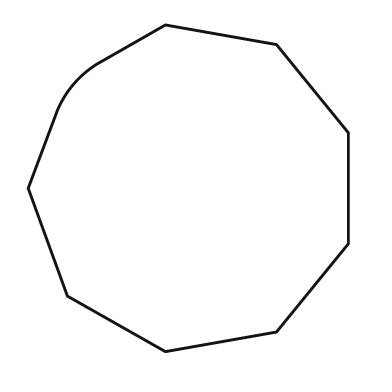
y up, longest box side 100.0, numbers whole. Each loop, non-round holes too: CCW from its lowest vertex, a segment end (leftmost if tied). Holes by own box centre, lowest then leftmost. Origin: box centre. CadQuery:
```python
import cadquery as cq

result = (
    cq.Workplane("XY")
    .moveTo(-7.0, -50.0)
    .lineTo(27.0, -44.0)
    .lineTo(49.0, -17.0)
    .lineTo(49.0, 17.0)
    .lineTo(27.0, 44.0)
    .lineTo(-7.0, 50.0)
    .lineTo(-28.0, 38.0)
    .threePointArc((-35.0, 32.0), (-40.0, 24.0))
    .lineTo(-49.0, 0.0)
    .lineTo(-37.0, -33.0)
    .close()
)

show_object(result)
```